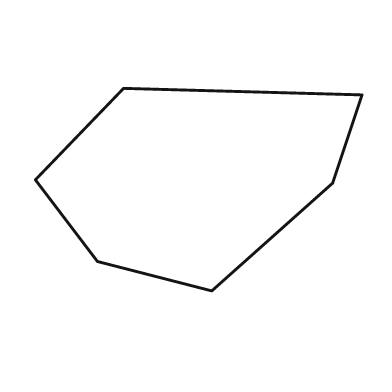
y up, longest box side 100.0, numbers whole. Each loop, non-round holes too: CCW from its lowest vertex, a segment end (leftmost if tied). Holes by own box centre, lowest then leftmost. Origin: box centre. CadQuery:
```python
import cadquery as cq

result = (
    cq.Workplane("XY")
    .moveTo(4.0, -31.0)
    .lineTo(41.0, 2.0)
    .lineTo(50.0, 29.0)
    .lineTo(-23.0, 31.0)
    .lineTo(-50.0, 3.0)
    .lineTo(-31.0, -22.0)
    .close()
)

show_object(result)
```